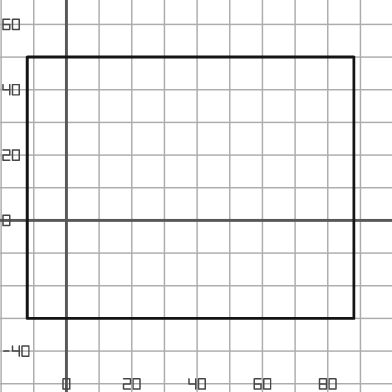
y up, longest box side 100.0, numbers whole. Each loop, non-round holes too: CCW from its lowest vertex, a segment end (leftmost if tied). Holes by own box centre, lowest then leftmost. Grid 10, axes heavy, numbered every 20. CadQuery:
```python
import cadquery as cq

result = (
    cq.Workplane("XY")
    .moveTo(-12.0, -30.0)
    .lineTo(88.0, -30.0)
    .lineTo(88.0, 50.0)
    .lineTo(-12.0, 50.0)
    .close()
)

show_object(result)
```